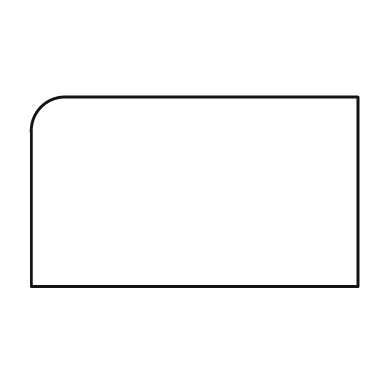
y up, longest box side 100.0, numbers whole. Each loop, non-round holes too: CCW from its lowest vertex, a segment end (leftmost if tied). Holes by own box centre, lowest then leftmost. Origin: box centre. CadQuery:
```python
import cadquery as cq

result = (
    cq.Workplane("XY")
    .moveTo(-50.0, -29.0)
    .lineTo(50.0, -29.0)
    .lineTo(50.0, 29.0)
    .lineTo(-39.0, 29.0)
    .threePointArc((-47.0, 26.0), (-50.0, 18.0))
    .close()
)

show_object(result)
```